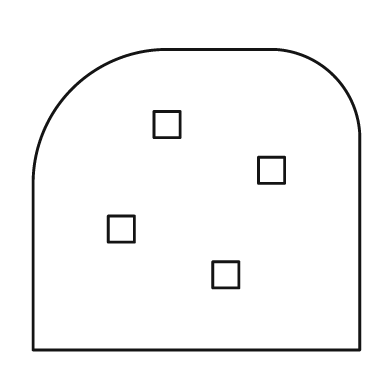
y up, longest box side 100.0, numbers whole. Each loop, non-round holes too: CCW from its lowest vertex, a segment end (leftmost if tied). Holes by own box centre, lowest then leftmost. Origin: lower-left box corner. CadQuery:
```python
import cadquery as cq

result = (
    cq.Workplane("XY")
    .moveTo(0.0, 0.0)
    .lineTo(100.0, 0.0)
    .lineTo(100.0, 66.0)
    .threePointArc((92.0, 84.0), (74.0, 92.0))
    .lineTo(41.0, 92.0)
    .threePointArc((12.0, 80.0), (0.0, 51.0))
    .close()
    .moveTo(55.0, 19.0)
    .lineTo(63.0, 19.0)
    .lineTo(63.0, 27.0)
    .lineTo(55.0, 27.0)
    .close()
    .moveTo(23.0, 33.0)
    .lineTo(31.0, 33.0)
    .lineTo(31.0, 41.0)
    .lineTo(23.0, 41.0)
    .close()
    .moveTo(69.0, 51.0)
    .lineTo(77.0, 51.0)
    .lineTo(77.0, 59.0)
    .lineTo(69.0, 59.0)
    .close()
    .moveTo(37.0, 65.0)
    .lineTo(45.0, 65.0)
    .lineTo(45.0, 73.0)
    .lineTo(37.0, 73.0)
    .close()
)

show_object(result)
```